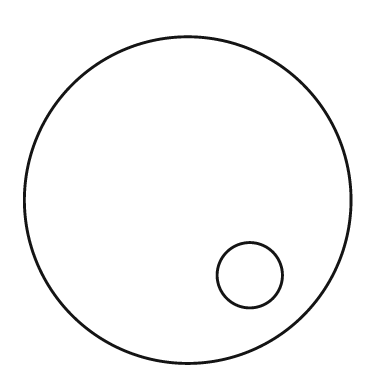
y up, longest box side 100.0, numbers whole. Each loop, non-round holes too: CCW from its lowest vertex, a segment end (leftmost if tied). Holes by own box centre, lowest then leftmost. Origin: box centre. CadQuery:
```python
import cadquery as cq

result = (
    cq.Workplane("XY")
    .moveTo(0.0, 0.0)
    .circle(50.0)
    .moveTo(19.0, -23.0)
    .circle(10.0)
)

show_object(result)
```